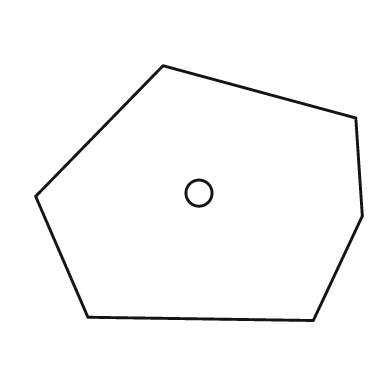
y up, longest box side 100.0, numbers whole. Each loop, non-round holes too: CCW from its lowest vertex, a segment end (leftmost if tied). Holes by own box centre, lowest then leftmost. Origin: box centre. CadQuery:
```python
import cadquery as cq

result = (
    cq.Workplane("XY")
    .moveTo(35.0, -39.0)
    .lineTo(50.0, -7.0)
    .lineTo(48.0, 23.0)
    .lineTo(-11.0, 39.0)
    .lineTo(-50.0, -1.0)
    .lineTo(-34.0, -38.0)
    .close()
    .moveTo(0.0, 0.0)
    .circle(4.0)
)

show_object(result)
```